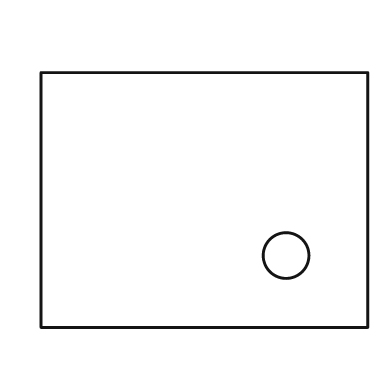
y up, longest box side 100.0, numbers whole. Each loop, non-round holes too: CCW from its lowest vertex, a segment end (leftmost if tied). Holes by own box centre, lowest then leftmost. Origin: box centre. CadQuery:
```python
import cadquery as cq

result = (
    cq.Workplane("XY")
    .moveTo(-50.0, -39.0)
    .lineTo(50.0, -39.0)
    .lineTo(50.0, 39.0)
    .lineTo(-50.0, 39.0)
    .close()
    .moveTo(25.0, -17.0)
    .circle(7.0)
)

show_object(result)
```